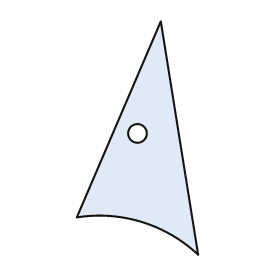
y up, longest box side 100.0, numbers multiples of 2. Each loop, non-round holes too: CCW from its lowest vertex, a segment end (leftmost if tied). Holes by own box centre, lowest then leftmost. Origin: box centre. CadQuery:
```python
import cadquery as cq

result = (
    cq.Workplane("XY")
    .moveTo(26.0, -50.0)
    .lineTo(10.0, 50.0)
    .lineTo(-26.0, -34.0)
    .threePointArc((2.0, -36.0), (26.0, -50.0))
    .close()
    .moveTo(0.0, 2.0)
    .circle(4.0)
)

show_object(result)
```